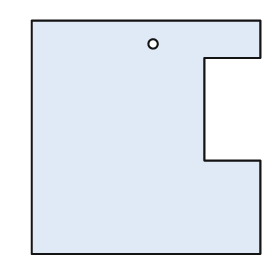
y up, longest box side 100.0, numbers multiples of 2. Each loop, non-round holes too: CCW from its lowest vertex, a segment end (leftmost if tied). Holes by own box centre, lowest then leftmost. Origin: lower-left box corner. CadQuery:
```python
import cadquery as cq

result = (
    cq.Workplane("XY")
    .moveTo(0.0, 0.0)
    .lineTo(98.0, 0.0)
    .lineTo(98.0, 40.0)
    .lineTo(74.0, 40.0)
    .lineTo(74.0, 84.0)
    .lineTo(98.0, 84.0)
    .lineTo(98.0, 100.0)
    .lineTo(0.0, 100.0)
    .close()
    .moveTo(52.0, 90.0)
    .circle(2.0)
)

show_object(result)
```